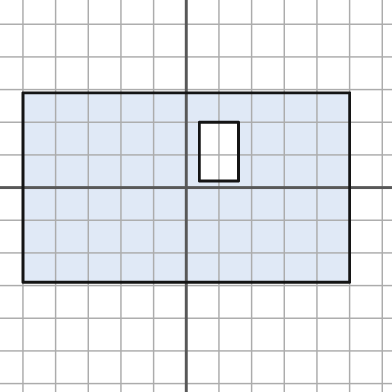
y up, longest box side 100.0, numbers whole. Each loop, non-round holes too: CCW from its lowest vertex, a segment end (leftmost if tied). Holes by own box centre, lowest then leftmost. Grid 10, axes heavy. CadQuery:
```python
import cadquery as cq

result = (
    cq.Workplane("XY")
    .moveTo(-50.0, -29.0)
    .lineTo(50.0, -29.0)
    .lineTo(50.0, 29.0)
    .lineTo(-50.0, 29.0)
    .close()
    .moveTo(4.0, 2.0)
    .lineTo(16.0, 2.0)
    .lineTo(16.0, 20.0)
    .lineTo(4.0, 20.0)
    .close()
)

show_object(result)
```